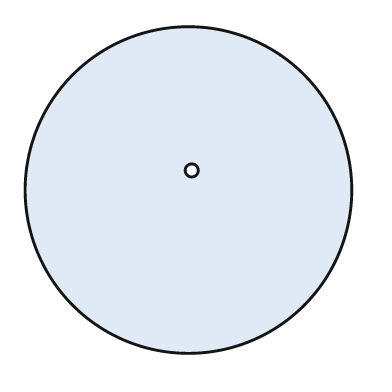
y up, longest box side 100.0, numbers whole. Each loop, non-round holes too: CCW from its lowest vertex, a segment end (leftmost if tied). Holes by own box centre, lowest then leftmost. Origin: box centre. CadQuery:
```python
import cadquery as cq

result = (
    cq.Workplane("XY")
    .moveTo(0.0, 0.0)
    .circle(50.0)
    .moveTo(1.0, 6.0)
    .circle(2.0)
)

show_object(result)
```